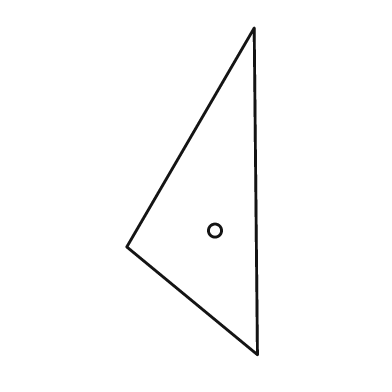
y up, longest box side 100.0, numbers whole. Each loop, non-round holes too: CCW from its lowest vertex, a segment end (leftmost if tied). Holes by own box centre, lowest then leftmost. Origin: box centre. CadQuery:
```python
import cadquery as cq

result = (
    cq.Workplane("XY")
    .moveTo(20.0, -50.0)
    .lineTo(19.0, 50.0)
    .lineTo(-20.0, -17.0)
    .close()
    .moveTo(7.0, -12.0)
    .circle(2.0)
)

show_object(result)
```